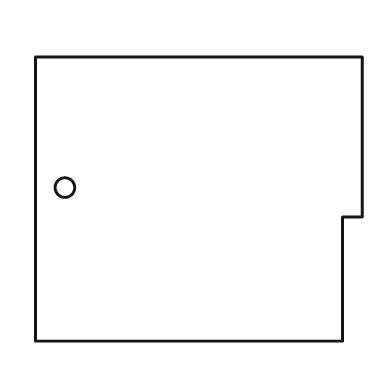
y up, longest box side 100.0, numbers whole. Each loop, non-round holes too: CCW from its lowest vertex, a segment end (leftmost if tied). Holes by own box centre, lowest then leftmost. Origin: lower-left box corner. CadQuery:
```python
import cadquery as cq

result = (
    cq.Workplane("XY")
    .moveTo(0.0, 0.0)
    .lineTo(94.0, 0.0)
    .lineTo(94.0, 38.0)
    .lineTo(100.0, 38.0)
    .lineTo(100.0, 87.0)
    .lineTo(0.0, 87.0)
    .close()
    .moveTo(9.0, 47.0)
    .circle(3.0)
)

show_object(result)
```